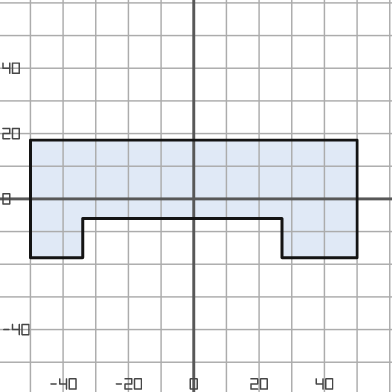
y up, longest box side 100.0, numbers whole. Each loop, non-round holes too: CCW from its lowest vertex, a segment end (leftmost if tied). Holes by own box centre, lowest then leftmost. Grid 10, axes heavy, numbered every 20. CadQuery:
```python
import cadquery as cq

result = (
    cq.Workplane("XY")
    .moveTo(-50.0, -18.0)
    .lineTo(-34.0, -18.0)
    .lineTo(-34.0, -6.0)
    .lineTo(27.0, -6.0)
    .lineTo(27.0, -18.0)
    .lineTo(50.0, -18.0)
    .lineTo(50.0, 18.0)
    .lineTo(-50.0, 18.0)
    .close()
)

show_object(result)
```